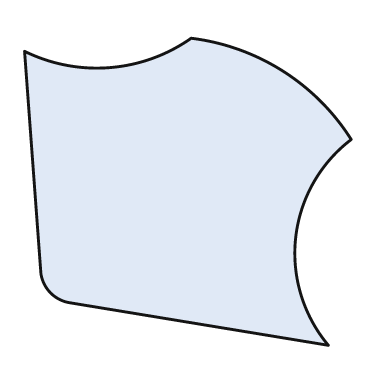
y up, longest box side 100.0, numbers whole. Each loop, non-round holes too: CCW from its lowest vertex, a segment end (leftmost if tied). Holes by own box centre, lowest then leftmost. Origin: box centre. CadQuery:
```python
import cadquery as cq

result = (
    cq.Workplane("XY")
    .moveTo(43.0, -47.0)
    .threePointArc((33.0, -14.0), (50.0, 16.0))
    .threePointArc((29.0, 37.0), (1.0, 47.0))
    .threePointArc((-24.0, 38.0), (-50.0, 43.0))
    .lineTo(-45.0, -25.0)
    .threePointArc((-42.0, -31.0), (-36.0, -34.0))
    .close()
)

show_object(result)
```